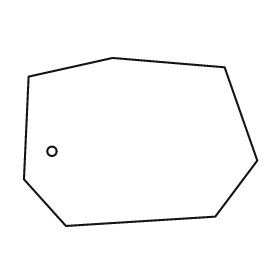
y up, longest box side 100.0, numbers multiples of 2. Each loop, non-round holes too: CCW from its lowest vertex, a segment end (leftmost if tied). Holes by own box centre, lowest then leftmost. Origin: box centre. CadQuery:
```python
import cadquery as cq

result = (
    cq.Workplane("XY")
    .moveTo(-32.0, -36.0)
    .lineTo(32.0, -32.0)
    .lineTo(50.0, -8.0)
    .lineTo(36.0, 32.0)
    .lineTo(-12.0, 36.0)
    .lineTo(-48.0, 28.0)
    .lineTo(-50.0, -16.0)
    .close()
    .moveTo(-38.0, -4.0)
    .circle(2.0)
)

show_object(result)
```